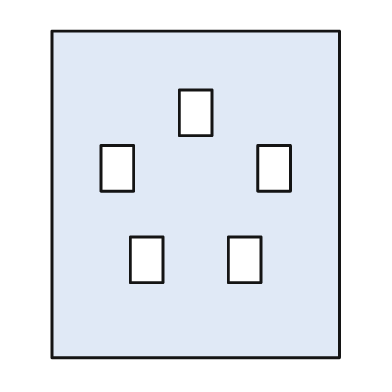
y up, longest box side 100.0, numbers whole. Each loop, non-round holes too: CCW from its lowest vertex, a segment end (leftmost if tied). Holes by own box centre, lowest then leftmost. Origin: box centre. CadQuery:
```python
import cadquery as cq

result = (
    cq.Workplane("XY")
    .moveTo(-44.0, -50.0)
    .lineTo(44.0, -50.0)
    .lineTo(44.0, 50.0)
    .lineTo(-44.0, 50.0)
    .close()
    .moveTo(-20.0, -27.0)
    .lineTo(-10.0, -27.0)
    .lineTo(-10.0, -13.0)
    .lineTo(-20.0, -13.0)
    .close()
    .moveTo(10.0, -27.0)
    .lineTo(20.0, -27.0)
    .lineTo(20.0, -13.0)
    .lineTo(10.0, -13.0)
    .close()
    .moveTo(-29.0, 1.0)
    .lineTo(-19.0, 1.0)
    .lineTo(-19.0, 15.0)
    .lineTo(-29.0, 15.0)
    .close()
    .moveTo(19.0, 1.0)
    .lineTo(29.0, 1.0)
    .lineTo(29.0, 15.0)
    .lineTo(19.0, 15.0)
    .close()
    .moveTo(-5.0, 18.0)
    .lineTo(5.0, 18.0)
    .lineTo(5.0, 32.0)
    .lineTo(-5.0, 32.0)
    .close()
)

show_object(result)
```